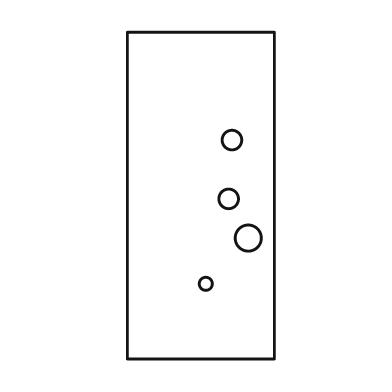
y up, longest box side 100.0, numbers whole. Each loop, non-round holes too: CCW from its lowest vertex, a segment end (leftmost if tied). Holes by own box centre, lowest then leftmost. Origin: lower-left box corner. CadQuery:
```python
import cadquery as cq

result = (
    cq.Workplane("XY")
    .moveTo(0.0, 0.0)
    .lineTo(45.0, 0.0)
    .lineTo(45.0, 100.0)
    .lineTo(0.0, 100.0)
    .close()
    .moveTo(24.0, 23.0)
    .circle(2.0)
    .moveTo(37.0, 37.0)
    .circle(4.0)
    .moveTo(31.0, 49.0)
    .circle(3.0)
    .moveTo(32.0, 67.0)
    .circle(3.0)
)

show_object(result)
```